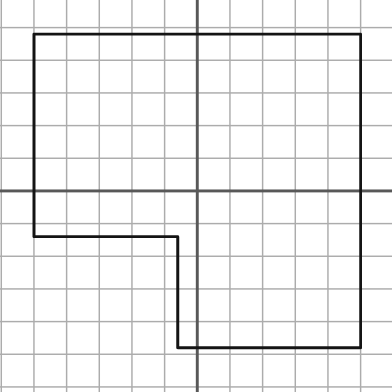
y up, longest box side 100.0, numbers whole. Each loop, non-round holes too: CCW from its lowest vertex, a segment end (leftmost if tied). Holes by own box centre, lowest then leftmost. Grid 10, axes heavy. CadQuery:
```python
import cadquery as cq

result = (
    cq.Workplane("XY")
    .moveTo(-6.0, -48.0)
    .lineTo(50.0, -48.0)
    .lineTo(50.0, 48.0)
    .lineTo(-50.0, 48.0)
    .lineTo(-50.0, -14.0)
    .lineTo(-6.0, -14.0)
    .close()
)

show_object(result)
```